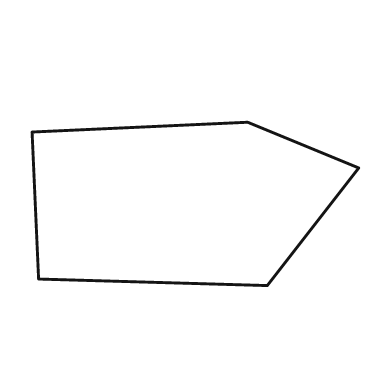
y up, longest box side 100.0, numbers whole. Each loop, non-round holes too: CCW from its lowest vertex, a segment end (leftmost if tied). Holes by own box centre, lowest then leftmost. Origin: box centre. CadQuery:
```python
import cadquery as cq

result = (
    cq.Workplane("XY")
    .moveTo(22.0, -25.0)
    .lineTo(50.0, 11.0)
    .lineTo(16.0, 25.0)
    .lineTo(-50.0, 22.0)
    .lineTo(-48.0, -23.0)
    .close()
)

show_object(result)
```